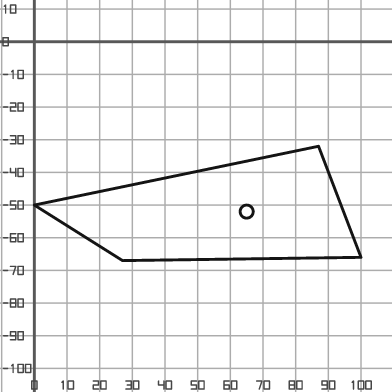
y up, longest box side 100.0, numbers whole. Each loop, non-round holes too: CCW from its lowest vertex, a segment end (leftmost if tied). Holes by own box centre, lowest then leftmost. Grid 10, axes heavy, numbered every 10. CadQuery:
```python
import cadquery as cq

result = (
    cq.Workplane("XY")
    .moveTo(27.0, -67.0)
    .lineTo(100.0, -66.0)
    .lineTo(87.0, -32.0)
    .lineTo(0.0, -50.0)
    .close()
    .moveTo(65.0, -52.0)
    .circle(2.0)
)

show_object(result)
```